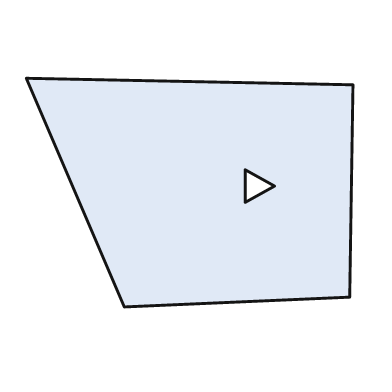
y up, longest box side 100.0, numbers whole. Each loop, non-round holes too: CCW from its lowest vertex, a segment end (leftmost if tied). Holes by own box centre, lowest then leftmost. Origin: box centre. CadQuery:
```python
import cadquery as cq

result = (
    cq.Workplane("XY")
    .moveTo(-20.0, -35.0)
    .lineTo(49.0, -32.0)
    .lineTo(50.0, 33.0)
    .lineTo(-50.0, 35.0)
    .close()
    .moveTo(17.0, -3.0)
    .lineTo(26.0, 2.0)
    .lineTo(17.0, 7.0)
    .close()
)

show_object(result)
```